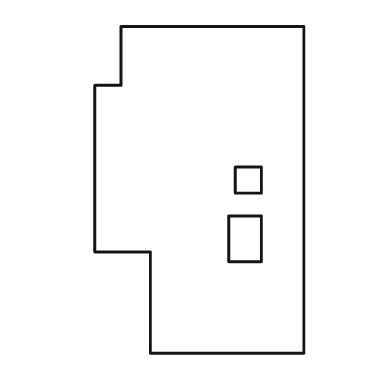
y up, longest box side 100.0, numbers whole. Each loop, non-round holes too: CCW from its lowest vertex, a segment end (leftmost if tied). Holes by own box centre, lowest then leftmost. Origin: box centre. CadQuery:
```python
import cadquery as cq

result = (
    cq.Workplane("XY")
    .moveTo(-15.0, -50.0)
    .lineTo(32.0, -50.0)
    .lineTo(32.0, 50.0)
    .lineTo(-24.0, 50.0)
    .lineTo(-24.0, 32.0)
    .lineTo(-32.0, 32.0)
    .lineTo(-32.0, -19.0)
    .lineTo(-15.0, -19.0)
    .close()
    .moveTo(9.0, -22.0)
    .lineTo(19.0, -22.0)
    .lineTo(19.0, -8.0)
    .lineTo(9.0, -8.0)
    .close()
    .moveTo(11.0, -1.0)
    .lineTo(19.0, -1.0)
    .lineTo(19.0, 7.0)
    .lineTo(11.0, 7.0)
    .close()
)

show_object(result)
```